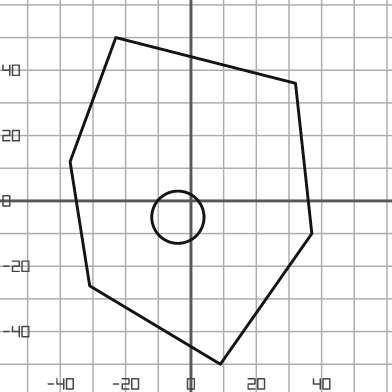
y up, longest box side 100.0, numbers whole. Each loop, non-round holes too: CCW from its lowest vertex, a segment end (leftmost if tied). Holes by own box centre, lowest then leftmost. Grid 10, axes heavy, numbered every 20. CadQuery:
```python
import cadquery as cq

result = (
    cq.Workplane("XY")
    .moveTo(9.0, -50.0)
    .lineTo(37.0, -10.0)
    .lineTo(32.0, 36.0)
    .lineTo(-23.0, 50.0)
    .lineTo(-37.0, 12.0)
    .lineTo(-31.0, -26.0)
    .close()
    .moveTo(-4.0, -5.0)
    .circle(8.0)
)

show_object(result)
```